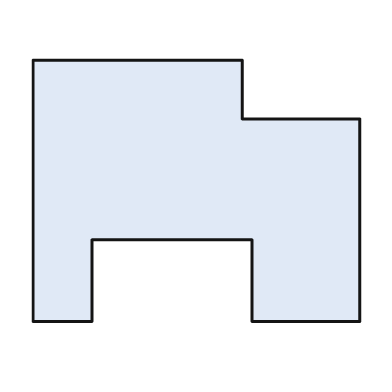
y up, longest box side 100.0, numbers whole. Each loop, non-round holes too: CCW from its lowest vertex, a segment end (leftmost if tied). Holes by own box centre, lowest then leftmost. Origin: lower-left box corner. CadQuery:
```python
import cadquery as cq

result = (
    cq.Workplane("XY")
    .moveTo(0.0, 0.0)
    .lineTo(18.0, 0.0)
    .lineTo(18.0, 25.0)
    .lineTo(67.0, 25.0)
    .lineTo(67.0, 0.0)
    .lineTo(100.0, 0.0)
    .lineTo(100.0, 62.0)
    .lineTo(64.0, 62.0)
    .lineTo(64.0, 80.0)
    .lineTo(0.0, 80.0)
    .close()
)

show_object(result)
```